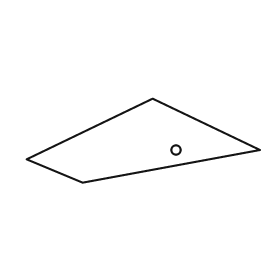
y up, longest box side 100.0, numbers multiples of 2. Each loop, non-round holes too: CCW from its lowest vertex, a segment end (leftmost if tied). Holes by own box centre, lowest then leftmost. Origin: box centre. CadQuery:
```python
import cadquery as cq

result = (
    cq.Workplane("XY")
    .moveTo(-26.0, -18.0)
    .lineTo(50.0, -4.0)
    .lineTo(4.0, 18.0)
    .lineTo(-50.0, -8.0)
    .close()
    .moveTo(14.0, -4.0)
    .circle(2.0)
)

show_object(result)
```